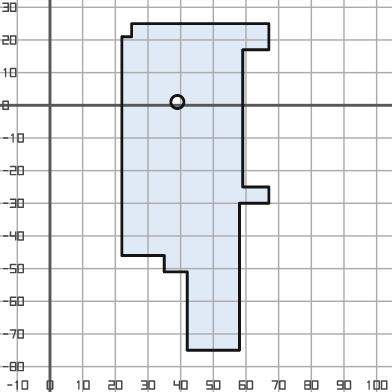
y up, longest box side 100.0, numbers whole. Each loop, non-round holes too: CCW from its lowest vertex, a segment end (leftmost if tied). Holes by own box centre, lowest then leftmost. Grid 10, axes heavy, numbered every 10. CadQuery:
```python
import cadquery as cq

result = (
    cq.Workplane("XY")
    .moveTo(42.0, -75.0)
    .lineTo(58.0, -75.0)
    .lineTo(58.0, -30.0)
    .lineTo(67.0, -30.0)
    .lineTo(67.0, -25.0)
    .lineTo(59.0, -25.0)
    .lineTo(59.0, 17.0)
    .lineTo(67.0, 17.0)
    .lineTo(67.0, 25.0)
    .lineTo(25.0, 25.0)
    .lineTo(25.0, 21.0)
    .lineTo(22.0, 21.0)
    .lineTo(22.0, -46.0)
    .lineTo(35.0, -46.0)
    .lineTo(35.0, -51.0)
    .lineTo(42.0, -51.0)
    .close()
    .moveTo(39.0, 1.0)
    .circle(2.0)
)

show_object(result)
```